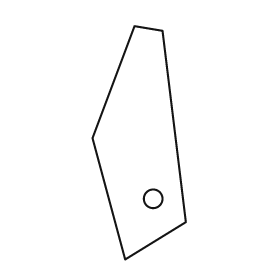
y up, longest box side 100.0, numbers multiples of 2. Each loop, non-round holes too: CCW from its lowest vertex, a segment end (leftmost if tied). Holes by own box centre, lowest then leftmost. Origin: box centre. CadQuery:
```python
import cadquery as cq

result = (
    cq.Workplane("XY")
    .moveTo(-6.0, -50.0)
    .lineTo(20.0, -34.0)
    .lineTo(10.0, 48.0)
    .lineTo(-2.0, 50.0)
    .lineTo(-20.0, 2.0)
    .close()
    .moveTo(6.0, -24.0)
    .circle(4.0)
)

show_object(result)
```